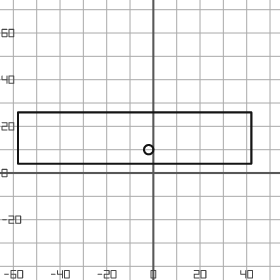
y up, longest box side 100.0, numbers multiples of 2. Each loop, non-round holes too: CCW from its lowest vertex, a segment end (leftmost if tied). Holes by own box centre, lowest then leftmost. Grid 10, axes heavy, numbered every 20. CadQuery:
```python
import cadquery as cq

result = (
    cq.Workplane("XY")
    .moveTo(-58.0, 4.0)
    .lineTo(42.0, 4.0)
    .lineTo(42.0, 26.0)
    .lineTo(-58.0, 26.0)
    .close()
    .moveTo(-2.0, 10.0)
    .circle(2.0)
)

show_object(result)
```